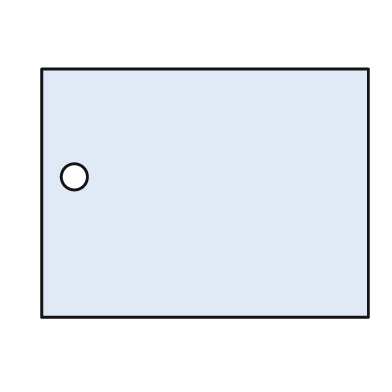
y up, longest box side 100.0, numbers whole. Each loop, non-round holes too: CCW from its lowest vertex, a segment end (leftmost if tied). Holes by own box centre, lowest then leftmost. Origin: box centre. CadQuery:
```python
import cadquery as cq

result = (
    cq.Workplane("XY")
    .moveTo(-50.0, -38.0)
    .lineTo(50.0, -38.0)
    .lineTo(50.0, 38.0)
    .lineTo(-50.0, 38.0)
    .close()
    .moveTo(-40.0, 5.0)
    .circle(4.0)
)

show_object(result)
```